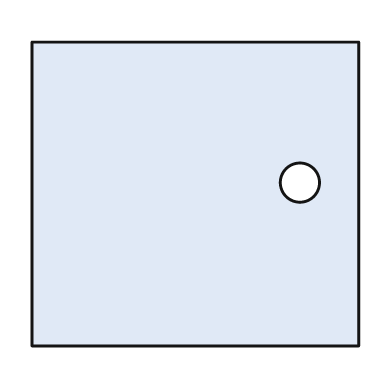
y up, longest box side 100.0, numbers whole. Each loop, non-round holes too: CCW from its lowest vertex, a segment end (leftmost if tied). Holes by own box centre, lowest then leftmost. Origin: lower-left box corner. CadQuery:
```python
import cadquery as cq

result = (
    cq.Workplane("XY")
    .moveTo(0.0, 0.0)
    .lineTo(100.0, 0.0)
    .lineTo(100.0, 93.0)
    .lineTo(0.0, 93.0)
    .close()
    .moveTo(82.0, 50.0)
    .circle(6.0)
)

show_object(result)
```